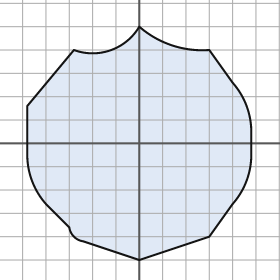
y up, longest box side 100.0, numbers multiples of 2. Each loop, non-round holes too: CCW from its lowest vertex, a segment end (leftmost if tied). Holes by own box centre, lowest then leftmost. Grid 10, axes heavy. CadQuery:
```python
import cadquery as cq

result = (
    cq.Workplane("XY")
    .moveTo(0.0, -50.0)
    .lineTo(30.0, -40.0)
    .lineTo(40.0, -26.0)
    .threePointArc((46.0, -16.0), (48.0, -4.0))
    .lineTo(48.0, 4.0)
    .threePointArc((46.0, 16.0), (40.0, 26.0))
    .lineTo(30.0, 40.0)
    .threePointArc((14.0, 42.0), (0.0, 50.0))
    .threePointArc((-12.0, 40.0), (-28.0, 40.0))
    .lineTo(-48.0, 16.0)
    .lineTo(-48.0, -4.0)
    .threePointArc((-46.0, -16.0), (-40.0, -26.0))
    .lineTo(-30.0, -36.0)
    .threePointArc((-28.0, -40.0), (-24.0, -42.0))
    .close()
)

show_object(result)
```